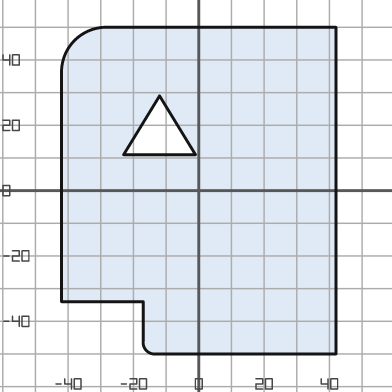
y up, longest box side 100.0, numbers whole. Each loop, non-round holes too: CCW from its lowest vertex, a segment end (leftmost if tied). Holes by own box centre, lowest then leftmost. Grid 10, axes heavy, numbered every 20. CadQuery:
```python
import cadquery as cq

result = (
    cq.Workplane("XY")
    .moveTo(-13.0, -50.0)
    .lineTo(42.0, -50.0)
    .lineTo(42.0, 50.0)
    .lineTo(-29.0, 50.0)
    .threePointArc((-38.0, 46.0), (-42.0, 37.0))
    .lineTo(-42.0, -34.0)
    .lineTo(-17.0, -34.0)
    .lineTo(-17.0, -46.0)
    .threePointArc((-16.0, -49.0), (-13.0, -50.0))
    .close()
    .moveTo(-23.0, 11.0)
    .lineTo(-1.0, 11.0)
    .lineTo(-12.0, 29.0)
    .close()
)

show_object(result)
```